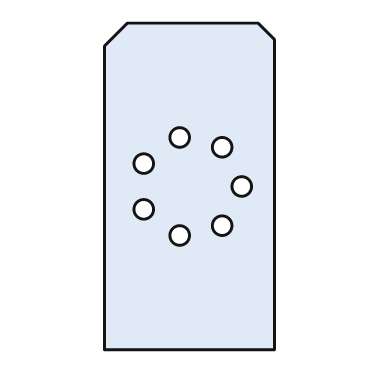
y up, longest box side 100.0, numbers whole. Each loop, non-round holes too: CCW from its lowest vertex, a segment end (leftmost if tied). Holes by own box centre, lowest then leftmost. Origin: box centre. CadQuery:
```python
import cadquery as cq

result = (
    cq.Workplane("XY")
    .moveTo(-26.0, -50.0)
    .lineTo(26.0, -50.0)
    .lineTo(26.0, 45.0)
    .lineTo(21.0, 50.0)
    .lineTo(-19.0, 50.0)
    .lineTo(-26.0, 43.0)
    .close()
    .moveTo(-3.0, -15.0)
    .circle(3.0)
    .moveTo(10.0, -12.0)
    .circle(3.0)
    .moveTo(-14.0, -7.0)
    .circle(3.0)
    .moveTo(16.0, 0.0)
    .circle(3.0)
    .moveTo(-14.0, 7.0)
    .circle(3.0)
    .moveTo(10.0, 12.0)
    .circle(3.0)
    .moveTo(-3.0, 15.0)
    .circle(3.0)
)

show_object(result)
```